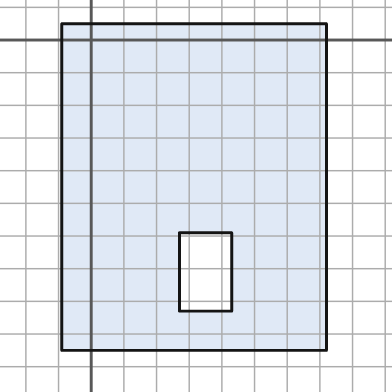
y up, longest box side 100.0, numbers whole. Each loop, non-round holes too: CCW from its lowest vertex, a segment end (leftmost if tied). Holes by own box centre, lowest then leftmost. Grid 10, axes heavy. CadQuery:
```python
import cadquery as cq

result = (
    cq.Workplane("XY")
    .moveTo(-9.0, -95.0)
    .lineTo(72.0, -95.0)
    .lineTo(72.0, 5.0)
    .lineTo(-9.0, 5.0)
    .close()
    .moveTo(27.0, -83.0)
    .lineTo(43.0, -83.0)
    .lineTo(43.0, -59.0)
    .lineTo(27.0, -59.0)
    .close()
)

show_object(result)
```